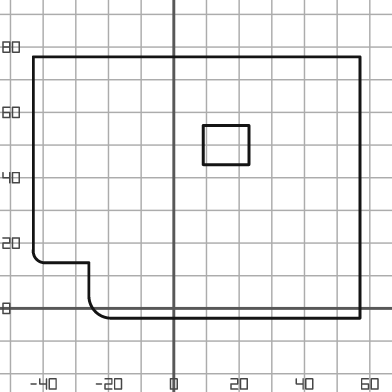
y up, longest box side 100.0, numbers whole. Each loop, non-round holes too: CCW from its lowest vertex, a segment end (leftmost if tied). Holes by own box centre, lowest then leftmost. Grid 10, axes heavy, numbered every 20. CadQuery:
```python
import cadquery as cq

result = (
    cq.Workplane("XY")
    .moveTo(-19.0, -3.0)
    .lineTo(57.0, -3.0)
    .lineTo(57.0, 77.0)
    .lineTo(-43.0, 77.0)
    .lineTo(-43.0, 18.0)
    .threePointArc((-42.0, 15.0), (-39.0, 14.0))
    .lineTo(-26.0, 14.0)
    .lineTo(-26.0, 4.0)
    .threePointArc((-24.0, -1.0), (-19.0, -3.0))
    .close()
    .moveTo(9.0, 44.0)
    .lineTo(23.0, 44.0)
    .lineTo(23.0, 56.0)
    .lineTo(9.0, 56.0)
    .close()
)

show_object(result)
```